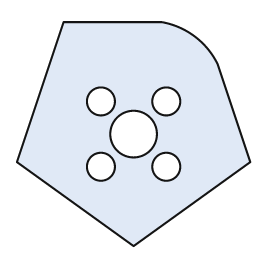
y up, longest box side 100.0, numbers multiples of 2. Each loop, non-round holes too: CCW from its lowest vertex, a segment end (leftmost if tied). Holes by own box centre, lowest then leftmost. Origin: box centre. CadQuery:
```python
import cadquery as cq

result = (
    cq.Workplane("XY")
    .moveTo(0.0, -48.0)
    .lineTo(50.0, -12.0)
    .lineTo(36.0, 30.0)
    .threePointArc((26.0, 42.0), (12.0, 48.0))
    .lineTo(-30.0, 48.0)
    .lineTo(-50.0, -12.0)
    .close()
    .moveTo(-14.0, -14.0)
    .circle(6.0)
    .moveTo(14.0, -14.0)
    .circle(6.0)
    .moveTo(0.0, 0.0)
    .circle(10.0)
    .moveTo(-14.0, 14.0)
    .circle(6.0)
    .moveTo(14.0, 14.0)
    .circle(6.0)
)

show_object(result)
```